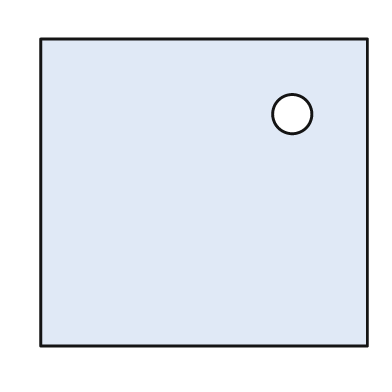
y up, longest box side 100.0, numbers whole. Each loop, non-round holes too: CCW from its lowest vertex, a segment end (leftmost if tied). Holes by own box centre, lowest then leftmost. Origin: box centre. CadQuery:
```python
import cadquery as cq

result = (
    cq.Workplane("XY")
    .moveTo(-50.0, -47.0)
    .lineTo(50.0, -47.0)
    .lineTo(50.0, 47.0)
    .lineTo(-50.0, 47.0)
    .close()
    .moveTo(27.0, 24.0)
    .circle(6.0)
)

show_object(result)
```